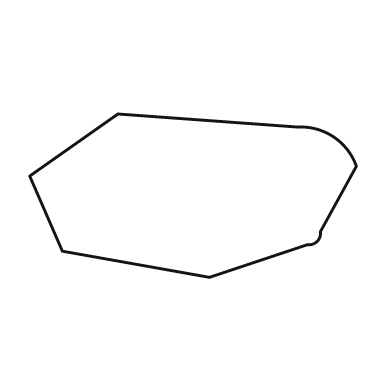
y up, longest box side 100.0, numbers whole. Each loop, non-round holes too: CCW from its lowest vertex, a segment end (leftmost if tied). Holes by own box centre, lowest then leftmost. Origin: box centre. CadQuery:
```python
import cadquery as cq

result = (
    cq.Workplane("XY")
    .moveTo(5.0, -25.0)
    .lineTo(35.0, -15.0)
    .threePointArc((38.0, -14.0), (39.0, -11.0))
    .lineTo(50.0, 9.0)
    .threePointArc((43.0, 18.0), (32.0, 21.0))
    .lineTo(-23.0, 25.0)
    .lineTo(-50.0, 6.0)
    .lineTo(-40.0, -17.0)
    .close()
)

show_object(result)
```